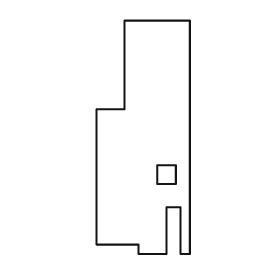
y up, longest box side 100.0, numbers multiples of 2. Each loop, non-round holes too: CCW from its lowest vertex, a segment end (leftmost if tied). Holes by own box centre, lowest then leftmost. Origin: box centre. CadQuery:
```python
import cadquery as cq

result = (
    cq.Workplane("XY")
    .moveTo(-2.0, -50.0)
    .lineTo(10.0, -50.0)
    .lineTo(10.0, -30.0)
    .lineTo(16.0, -30.0)
    .lineTo(16.0, -50.0)
    .lineTo(20.0, -50.0)
    .lineTo(20.0, 50.0)
    .lineTo(-8.0, 50.0)
    .lineTo(-8.0, 12.0)
    .lineTo(-20.0, 12.0)
    .lineTo(-20.0, -46.0)
    .lineTo(-2.0, -46.0)
    .close()
    .moveTo(6.0, -20.0)
    .lineTo(14.0, -20.0)
    .lineTo(14.0, -12.0)
    .lineTo(6.0, -12.0)
    .close()
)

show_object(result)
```